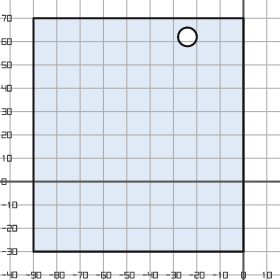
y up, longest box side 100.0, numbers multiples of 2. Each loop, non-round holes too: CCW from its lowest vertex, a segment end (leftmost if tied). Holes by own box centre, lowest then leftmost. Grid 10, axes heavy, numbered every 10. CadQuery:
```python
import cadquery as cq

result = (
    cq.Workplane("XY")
    .moveTo(-90.0, -30.0)
    .lineTo(0.0, -30.0)
    .lineTo(0.0, 70.0)
    .lineTo(-90.0, 70.0)
    .close()
    .moveTo(-24.0, 62.0)
    .circle(4.0)
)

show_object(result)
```